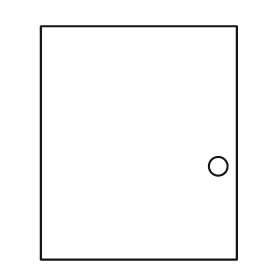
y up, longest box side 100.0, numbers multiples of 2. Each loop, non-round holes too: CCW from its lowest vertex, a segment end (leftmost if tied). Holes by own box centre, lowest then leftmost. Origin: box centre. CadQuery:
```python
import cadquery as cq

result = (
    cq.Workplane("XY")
    .moveTo(-42.0, -50.0)
    .lineTo(42.0, -50.0)
    .lineTo(42.0, 50.0)
    .lineTo(-42.0, 50.0)
    .close()
    .moveTo(34.0, -10.0)
    .circle(4.0)
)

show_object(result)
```